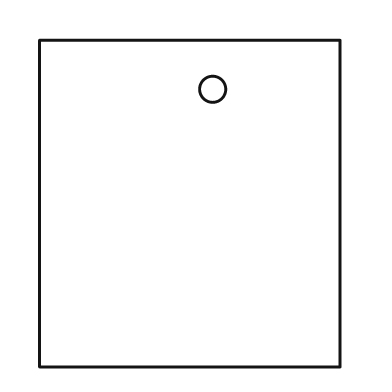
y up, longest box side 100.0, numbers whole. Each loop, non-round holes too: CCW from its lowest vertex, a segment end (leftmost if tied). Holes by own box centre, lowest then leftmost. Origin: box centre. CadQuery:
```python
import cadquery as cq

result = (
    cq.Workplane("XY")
    .moveTo(-46.0, -50.0)
    .lineTo(46.0, -50.0)
    .lineTo(46.0, 50.0)
    .lineTo(-46.0, 50.0)
    .close()
    .moveTo(7.0, 35.0)
    .circle(4.0)
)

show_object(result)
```